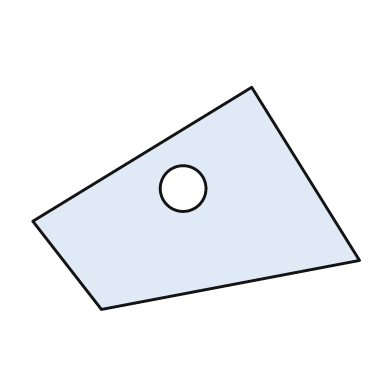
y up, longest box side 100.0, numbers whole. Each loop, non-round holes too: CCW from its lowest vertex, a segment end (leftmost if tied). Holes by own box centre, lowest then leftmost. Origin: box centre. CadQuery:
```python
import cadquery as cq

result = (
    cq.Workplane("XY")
    .moveTo(-29.0, -34.0)
    .lineTo(50.0, -19.0)
    .lineTo(17.0, 34.0)
    .lineTo(-50.0, -7.0)
    .close()
    .moveTo(-4.0, 3.0)
    .circle(7.0)
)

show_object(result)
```